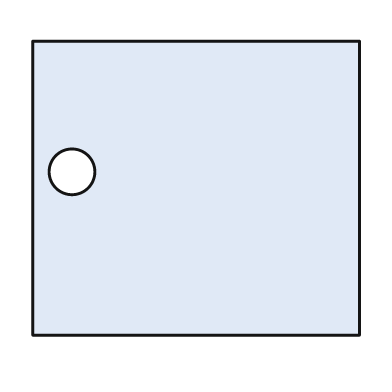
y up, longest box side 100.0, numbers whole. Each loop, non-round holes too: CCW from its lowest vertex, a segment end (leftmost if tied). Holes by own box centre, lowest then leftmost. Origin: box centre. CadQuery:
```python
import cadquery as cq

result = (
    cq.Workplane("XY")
    .moveTo(-50.0, -45.0)
    .lineTo(50.0, -45.0)
    .lineTo(50.0, 45.0)
    .lineTo(-50.0, 45.0)
    .close()
    .moveTo(-38.0, 5.0)
    .circle(7.0)
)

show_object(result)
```